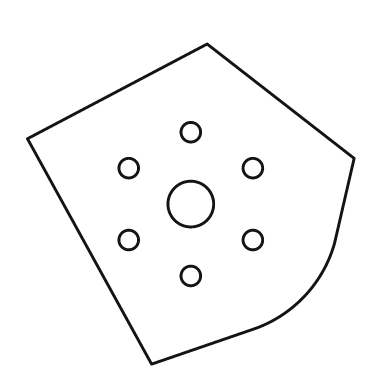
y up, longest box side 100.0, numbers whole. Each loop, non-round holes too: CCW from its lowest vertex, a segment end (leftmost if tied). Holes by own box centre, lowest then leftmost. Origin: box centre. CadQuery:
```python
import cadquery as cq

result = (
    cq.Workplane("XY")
    .moveTo(-12.0, -49.0)
    .lineTo(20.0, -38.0)
    .threePointArc((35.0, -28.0), (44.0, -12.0))
    .lineTo(50.0, 14.0)
    .lineTo(5.0, 49.0)
    .lineTo(-50.0, 20.0)
    .close()
    .moveTo(0.0, -22.0)
    .circle(3.0)
    .moveTo(-19.0, -11.0)
    .circle(3.0)
    .moveTo(19.0, -11.0)
    .circle(3.0)
    .moveTo(0.0, 0.0)
    .circle(7.0)
    .moveTo(-19.0, 11.0)
    .circle(3.0)
    .moveTo(19.0, 11.0)
    .circle(3.0)
    .moveTo(0.0, 22.0)
    .circle(3.0)
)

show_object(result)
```